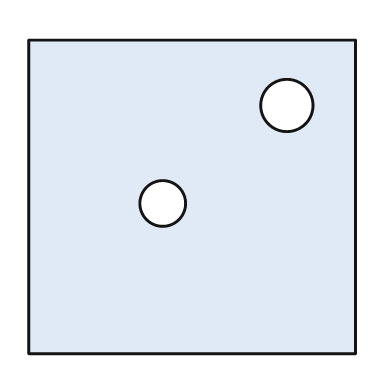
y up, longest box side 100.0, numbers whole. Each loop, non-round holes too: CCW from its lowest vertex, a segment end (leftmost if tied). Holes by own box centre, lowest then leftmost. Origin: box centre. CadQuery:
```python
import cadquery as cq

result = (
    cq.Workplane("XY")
    .moveTo(-50.0, -48.0)
    .lineTo(50.0, -48.0)
    .lineTo(50.0, 48.0)
    .lineTo(-50.0, 48.0)
    .close()
    .moveTo(-9.0, -2.0)
    .circle(7.0)
    .moveTo(29.0, 28.0)
    .circle(8.0)
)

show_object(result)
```